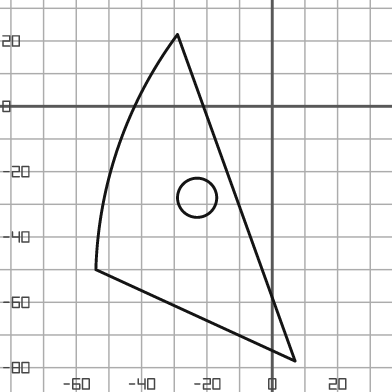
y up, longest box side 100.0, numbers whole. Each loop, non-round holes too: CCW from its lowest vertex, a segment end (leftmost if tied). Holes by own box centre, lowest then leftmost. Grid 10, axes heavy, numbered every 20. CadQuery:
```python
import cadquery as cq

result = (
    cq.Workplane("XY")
    .moveTo(7.0, -78.0)
    .lineTo(-29.0, 22.0)
    .threePointArc((-47.0, -12.0), (-54.0, -50.0))
    .close()
    .moveTo(-23.0, -28.0)
    .circle(6.0)
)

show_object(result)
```